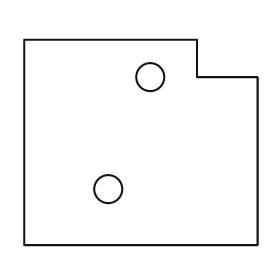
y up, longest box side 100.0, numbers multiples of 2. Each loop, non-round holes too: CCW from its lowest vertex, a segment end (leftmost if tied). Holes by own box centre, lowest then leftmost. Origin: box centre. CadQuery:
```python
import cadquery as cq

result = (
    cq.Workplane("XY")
    .moveTo(-50.0, -44.0)
    .lineTo(50.0, -44.0)
    .lineTo(50.0, 28.0)
    .lineTo(24.0, 28.0)
    .lineTo(24.0, 44.0)
    .lineTo(-50.0, 44.0)
    .close()
    .moveTo(-14.0, -20.0)
    .circle(6.0)
    .moveTo(4.0, 28.0)
    .circle(6.0)
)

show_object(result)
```